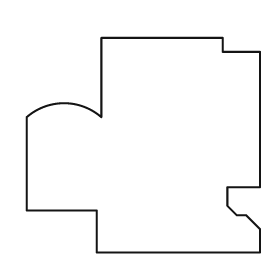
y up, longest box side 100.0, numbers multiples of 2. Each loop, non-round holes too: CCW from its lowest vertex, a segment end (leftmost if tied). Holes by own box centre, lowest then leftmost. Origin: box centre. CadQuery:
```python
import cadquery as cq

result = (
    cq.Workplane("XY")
    .moveTo(-20.0, -46.0)
    .lineTo(50.0, -46.0)
    .lineTo(50.0, -36.0)
    .lineTo(44.0, -30.0)
    .lineTo(40.0, -30.0)
    .lineTo(36.0, -26.0)
    .lineTo(36.0, -18.0)
    .lineTo(50.0, -18.0)
    .lineTo(50.0, 40.0)
    .lineTo(34.0, 40.0)
    .lineTo(34.0, 46.0)
    .lineTo(-18.0, 46.0)
    .lineTo(-18.0, 12.0)
    .threePointArc((-34.0, 18.0), (-50.0, 12.0))
    .lineTo(-50.0, -28.0)
    .lineTo(-20.0, -28.0)
    .close()
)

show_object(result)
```